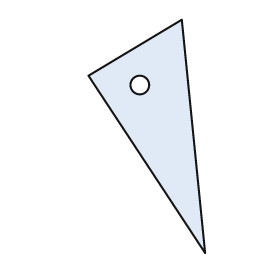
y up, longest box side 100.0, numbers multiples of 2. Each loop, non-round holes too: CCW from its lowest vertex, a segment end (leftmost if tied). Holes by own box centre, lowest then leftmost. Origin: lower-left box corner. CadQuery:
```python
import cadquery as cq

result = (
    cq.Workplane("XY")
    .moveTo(50.0, 0.0)
    .lineTo(40.0, 100.0)
    .lineTo(0.0, 76.0)
    .close()
    .moveTo(22.0, 72.0)
    .circle(4.0)
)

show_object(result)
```